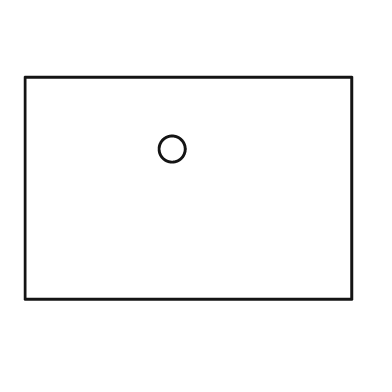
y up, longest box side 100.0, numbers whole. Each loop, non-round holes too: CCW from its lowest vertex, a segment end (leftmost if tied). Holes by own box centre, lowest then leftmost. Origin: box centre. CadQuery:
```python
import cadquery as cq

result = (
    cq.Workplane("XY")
    .moveTo(-50.0, -34.0)
    .lineTo(50.0, -34.0)
    .lineTo(50.0, 34.0)
    .lineTo(-50.0, 34.0)
    .close()
    .moveTo(-5.0, 12.0)
    .circle(4.0)
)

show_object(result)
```